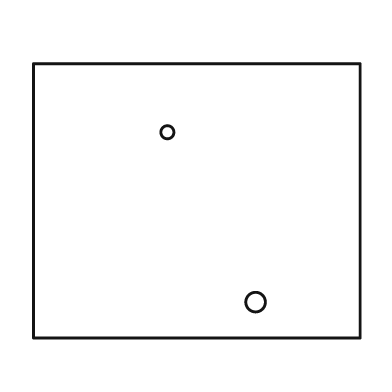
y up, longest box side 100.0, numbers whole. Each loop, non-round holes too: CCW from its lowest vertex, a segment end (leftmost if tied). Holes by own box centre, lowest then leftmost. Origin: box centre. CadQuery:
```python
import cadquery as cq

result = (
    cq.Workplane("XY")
    .moveTo(-50.0, -42.0)
    .lineTo(50.0, -42.0)
    .lineTo(50.0, 42.0)
    .lineTo(-50.0, 42.0)
    .close()
    .moveTo(18.0, -31.0)
    .circle(3.0)
    .moveTo(-9.0, 21.0)
    .circle(2.0)
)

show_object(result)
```